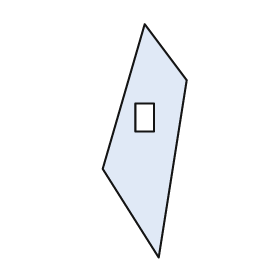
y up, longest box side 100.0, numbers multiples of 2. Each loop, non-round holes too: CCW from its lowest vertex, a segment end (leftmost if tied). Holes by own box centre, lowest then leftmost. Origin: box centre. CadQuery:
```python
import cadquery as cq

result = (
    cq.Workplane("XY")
    .moveTo(6.0, -50.0)
    .lineTo(18.0, 26.0)
    .lineTo(0.0, 50.0)
    .lineTo(-18.0, -12.0)
    .close()
    .moveTo(-4.0, 4.0)
    .lineTo(4.0, 4.0)
    .lineTo(4.0, 16.0)
    .lineTo(-4.0, 16.0)
    .close()
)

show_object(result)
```